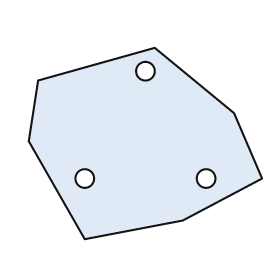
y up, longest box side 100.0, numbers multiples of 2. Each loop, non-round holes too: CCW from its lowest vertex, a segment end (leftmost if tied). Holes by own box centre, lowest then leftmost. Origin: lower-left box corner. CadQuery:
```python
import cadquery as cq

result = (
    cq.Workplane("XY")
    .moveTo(24.0, 0.0)
    .lineTo(66.0, 8.0)
    .lineTo(100.0, 26.0)
    .lineTo(88.0, 54.0)
    .lineTo(54.0, 82.0)
    .lineTo(4.0, 68.0)
    .lineTo(0.0, 42.0)
    .close()
    .moveTo(24.0, 26.0)
    .circle(4.0)
    .moveTo(76.0, 26.0)
    .circle(4.0)
    .moveTo(50.0, 72.0)
    .circle(4.0)
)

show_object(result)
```